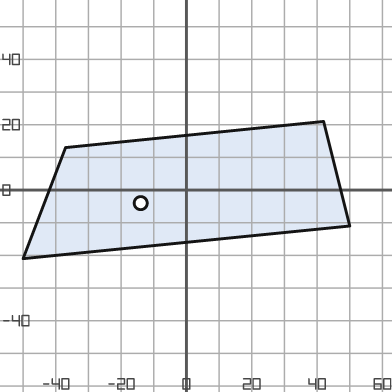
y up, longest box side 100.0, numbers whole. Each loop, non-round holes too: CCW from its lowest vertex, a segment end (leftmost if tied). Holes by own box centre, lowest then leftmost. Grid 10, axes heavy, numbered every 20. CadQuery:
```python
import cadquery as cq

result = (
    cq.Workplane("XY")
    .moveTo(-50.0, -21.0)
    .lineTo(50.0, -11.0)
    .lineTo(42.0, 21.0)
    .lineTo(-37.0, 13.0)
    .close()
    .moveTo(-14.0, -4.0)
    .circle(2.0)
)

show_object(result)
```